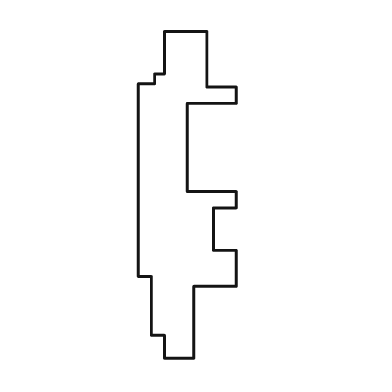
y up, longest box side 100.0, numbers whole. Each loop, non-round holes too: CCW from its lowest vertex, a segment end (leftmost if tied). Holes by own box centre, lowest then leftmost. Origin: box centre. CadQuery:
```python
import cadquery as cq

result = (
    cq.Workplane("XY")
    .moveTo(-7.0, -50.0)
    .lineTo(2.0, -50.0)
    .lineTo(2.0, -28.0)
    .lineTo(15.0, -28.0)
    .lineTo(15.0, -17.0)
    .lineTo(8.0, -17.0)
    .lineTo(8.0, -4.0)
    .lineTo(15.0, -4.0)
    .lineTo(15.0, 1.0)
    .lineTo(0.0, 1.0)
    .lineTo(0.0, 28.0)
    .lineTo(15.0, 28.0)
    .lineTo(15.0, 33.0)
    .lineTo(6.0, 33.0)
    .lineTo(6.0, 50.0)
    .lineTo(-7.0, 50.0)
    .lineTo(-7.0, 37.0)
    .lineTo(-10.0, 37.0)
    .lineTo(-10.0, 34.0)
    .lineTo(-15.0, 34.0)
    .lineTo(-15.0, -25.0)
    .lineTo(-11.0, -25.0)
    .lineTo(-11.0, -43.0)
    .lineTo(-7.0, -43.0)
    .close()
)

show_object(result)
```